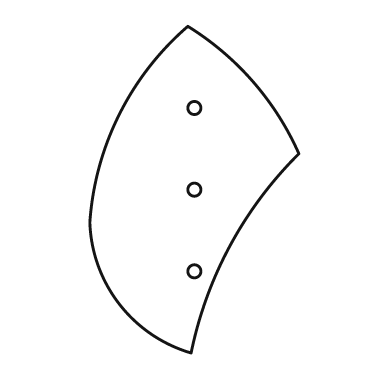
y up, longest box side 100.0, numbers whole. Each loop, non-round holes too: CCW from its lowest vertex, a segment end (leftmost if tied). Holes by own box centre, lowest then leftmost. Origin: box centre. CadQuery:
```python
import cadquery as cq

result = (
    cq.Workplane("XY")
    .moveTo(-1.0, -50.0)
    .threePointArc((11.0, -17.0), (32.0, 11.0))
    .threePointArc((18.0, 33.0), (-2.0, 50.0))
    .threePointArc((-23.0, 23.0), (-32.0, -10.0))
    .threePointArc((-23.0, -35.0), (-1.0, -50.0))
    .close()
    .moveTo(0.0, -25.0)
    .circle(2.0)
    .moveTo(0.0, 0.0)
    .circle(2.0)
    .moveTo(0.0, 25.0)
    .circle(2.0)
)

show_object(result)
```